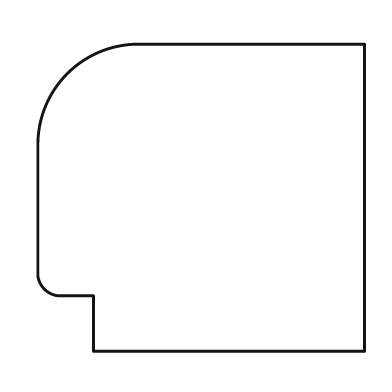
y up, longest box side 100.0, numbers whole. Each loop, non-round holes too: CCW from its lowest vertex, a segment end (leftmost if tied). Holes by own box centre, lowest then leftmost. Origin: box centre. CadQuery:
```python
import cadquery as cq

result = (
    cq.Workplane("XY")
    .moveTo(-33.0, -47.0)
    .lineTo(50.0, -47.0)
    .lineTo(50.0, 47.0)
    .lineTo(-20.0, 47.0)
    .threePointArc((-41.0, 38.0), (-50.0, 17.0))
    .lineTo(-50.0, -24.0)
    .threePointArc((-48.0, -28.0), (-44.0, -30.0))
    .lineTo(-33.0, -30.0)
    .close()
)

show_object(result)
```